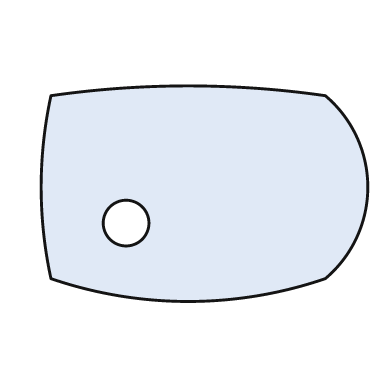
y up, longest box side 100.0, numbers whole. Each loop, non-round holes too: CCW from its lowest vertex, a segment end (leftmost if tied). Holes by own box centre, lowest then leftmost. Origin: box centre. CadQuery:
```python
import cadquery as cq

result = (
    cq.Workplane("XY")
    .moveTo(-47.0, -26.0)
    .threePointArc((-5.0, -33.0), (37.0, -26.0))
    .threePointArc((50.0, 2.0), (37.0, 30.0))
    .threePointArc((-5.0, 33.0), (-47.0, 30.0))
    .threePointArc((-50.0, 2.0), (-47.0, -26.0))
    .close()
    .moveTo(-24.0, -9.0)
    .circle(7.0)
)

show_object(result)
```